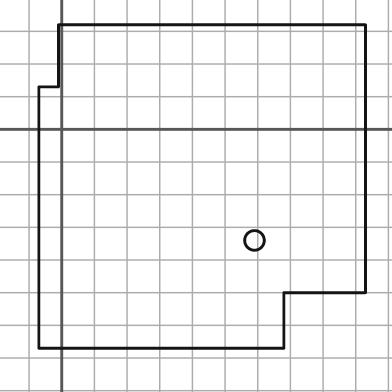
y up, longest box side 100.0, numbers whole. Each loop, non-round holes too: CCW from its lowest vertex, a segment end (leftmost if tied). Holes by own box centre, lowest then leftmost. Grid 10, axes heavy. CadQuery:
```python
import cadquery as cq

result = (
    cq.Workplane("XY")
    .moveTo(-7.0, -67.0)
    .lineTo(68.0, -67.0)
    .lineTo(68.0, -50.0)
    .lineTo(93.0, -50.0)
    .lineTo(93.0, 32.0)
    .lineTo(-1.0, 32.0)
    .lineTo(-1.0, 13.0)
    .lineTo(-7.0, 13.0)
    .close()
    .moveTo(59.0, -34.0)
    .circle(3.0)
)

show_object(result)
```